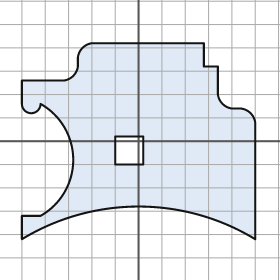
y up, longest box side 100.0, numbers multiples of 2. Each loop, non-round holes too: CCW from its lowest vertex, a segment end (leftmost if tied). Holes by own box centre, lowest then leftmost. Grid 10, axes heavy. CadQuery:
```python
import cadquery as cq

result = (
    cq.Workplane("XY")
    .moveTo(-50.0, -42.0)
    .threePointArc((0.0, -28.0), (50.0, -42.0))
    .lineTo(50.0, 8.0)
    .threePointArc((48.0, 12.0), (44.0, 14.0))
    .lineTo(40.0, 14.0)
    .threePointArc((36.0, 16.0), (34.0, 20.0))
    .lineTo(34.0, 32.0)
    .lineTo(28.0, 32.0)
    .lineTo(28.0, 42.0)
    .lineTo(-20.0, 42.0)
    .threePointArc((-24.0, 40.0), (-26.0, 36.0))
    .lineTo(-26.0, 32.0)
    .threePointArc((-28.0, 28.0), (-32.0, 26.0))
    .lineTo(-50.0, 26.0)
    .lineTo(-50.0, 16.0)
    .threePointArc((-46.0, 12.0), (-42.0, 16.0))
    .threePointArc((-28.0, -8.0), (-42.0, -32.0))
    .lineTo(-50.0, -32.0)
    .close()
    .moveTo(-10.0, -10.0)
    .lineTo(2.0, -10.0)
    .lineTo(2.0, 2.0)
    .lineTo(-10.0, 2.0)
    .close()
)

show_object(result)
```